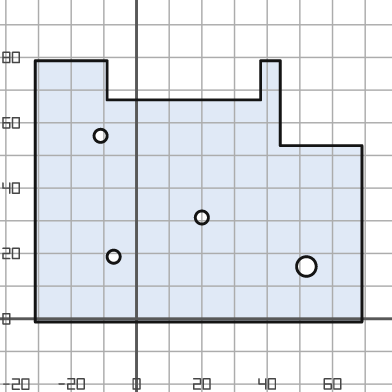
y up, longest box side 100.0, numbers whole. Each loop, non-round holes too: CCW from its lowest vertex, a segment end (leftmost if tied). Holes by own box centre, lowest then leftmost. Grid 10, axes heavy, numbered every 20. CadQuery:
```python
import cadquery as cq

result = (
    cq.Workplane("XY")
    .moveTo(-31.0, -1.0)
    .lineTo(69.0, -1.0)
    .lineTo(69.0, 53.0)
    .lineTo(44.0, 53.0)
    .lineTo(44.0, 79.0)
    .lineTo(38.0, 79.0)
    .lineTo(38.0, 67.0)
    .lineTo(-9.0, 67.0)
    .lineTo(-9.0, 79.0)
    .lineTo(-31.0, 79.0)
    .close()
    .moveTo(52.0, 16.0)
    .circle(3.0)
    .moveTo(-7.0, 19.0)
    .circle(2.0)
    .moveTo(20.0, 31.0)
    .circle(2.0)
    .moveTo(-11.0, 56.0)
    .circle(2.0)
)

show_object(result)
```